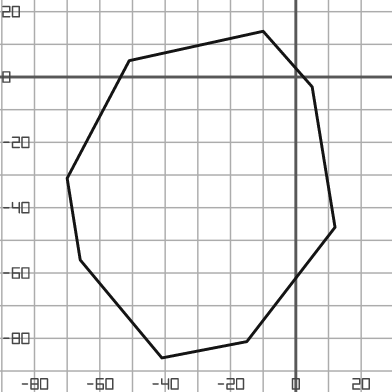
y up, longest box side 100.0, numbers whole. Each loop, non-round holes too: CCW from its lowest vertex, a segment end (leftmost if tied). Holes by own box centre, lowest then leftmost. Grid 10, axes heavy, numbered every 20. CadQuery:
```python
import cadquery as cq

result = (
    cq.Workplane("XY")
    .moveTo(-41.0, -86.0)
    .lineTo(-15.0, -81.0)
    .lineTo(12.0, -46.0)
    .lineTo(5.0, -3.0)
    .lineTo(-10.0, 14.0)
    .lineTo(-51.0, 5.0)
    .lineTo(-70.0, -31.0)
    .lineTo(-66.0, -56.0)
    .close()
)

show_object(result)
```